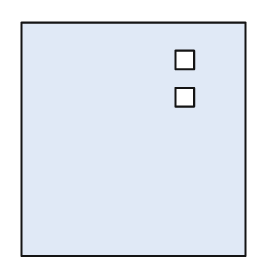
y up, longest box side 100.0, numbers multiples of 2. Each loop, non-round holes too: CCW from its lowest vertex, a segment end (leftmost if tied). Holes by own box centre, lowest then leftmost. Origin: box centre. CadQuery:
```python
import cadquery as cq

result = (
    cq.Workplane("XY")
    .moveTo(-48.0, -50.0)
    .lineTo(48.0, -50.0)
    .lineTo(48.0, 50.0)
    .lineTo(-48.0, 50.0)
    .close()
    .moveTo(18.0, 14.0)
    .lineTo(26.0, 14.0)
    .lineTo(26.0, 22.0)
    .lineTo(18.0, 22.0)
    .close()
    .moveTo(18.0, 30.0)
    .lineTo(26.0, 30.0)
    .lineTo(26.0, 38.0)
    .lineTo(18.0, 38.0)
    .close()
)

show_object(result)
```